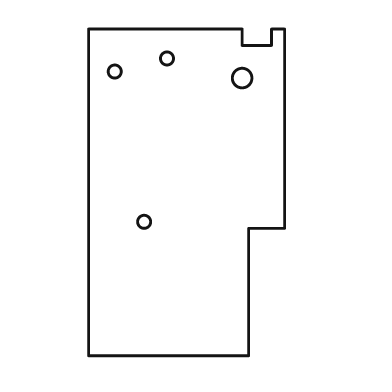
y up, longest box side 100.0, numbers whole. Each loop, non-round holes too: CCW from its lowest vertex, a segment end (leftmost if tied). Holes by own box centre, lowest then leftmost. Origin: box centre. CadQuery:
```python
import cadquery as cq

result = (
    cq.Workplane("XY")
    .moveTo(-30.0, -50.0)
    .lineTo(19.0, -50.0)
    .lineTo(19.0, -11.0)
    .lineTo(30.0, -11.0)
    .lineTo(30.0, 50.0)
    .lineTo(26.0, 50.0)
    .lineTo(26.0, 45.0)
    .lineTo(17.0, 45.0)
    .lineTo(17.0, 50.0)
    .lineTo(-30.0, 50.0)
    .close()
    .moveTo(-13.0, -9.0)
    .circle(2.0)
    .moveTo(17.0, 35.0)
    .circle(3.0)
    .moveTo(-22.0, 37.0)
    .circle(2.0)
    .moveTo(-6.0, 41.0)
    .circle(2.0)
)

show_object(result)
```